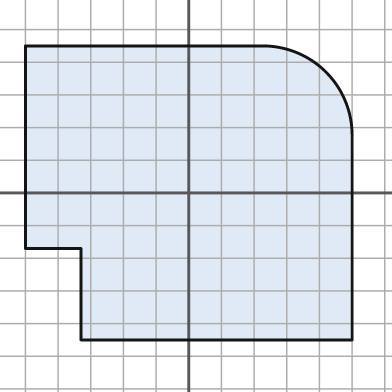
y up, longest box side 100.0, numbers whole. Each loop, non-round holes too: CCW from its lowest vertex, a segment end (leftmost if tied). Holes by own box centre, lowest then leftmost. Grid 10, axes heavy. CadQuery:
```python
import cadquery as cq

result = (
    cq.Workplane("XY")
    .moveTo(-33.0, -45.0)
    .lineTo(50.0, -45.0)
    .lineTo(50.0, 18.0)
    .threePointArc((42.0, 37.0), (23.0, 45.0))
    .lineTo(-50.0, 45.0)
    .lineTo(-50.0, -17.0)
    .lineTo(-33.0, -17.0)
    .close()
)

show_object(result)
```